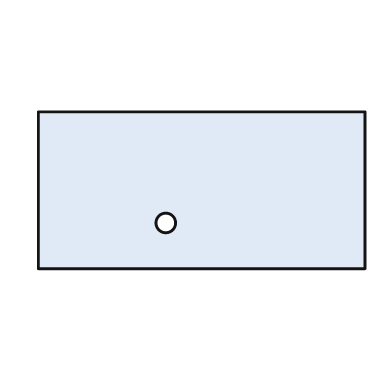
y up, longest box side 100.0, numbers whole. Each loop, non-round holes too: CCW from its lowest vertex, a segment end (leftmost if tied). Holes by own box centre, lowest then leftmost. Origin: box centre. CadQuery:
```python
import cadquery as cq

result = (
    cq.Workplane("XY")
    .moveTo(-50.0, -24.0)
    .lineTo(50.0, -24.0)
    .lineTo(50.0, 24.0)
    .lineTo(-50.0, 24.0)
    .close()
    .moveTo(-11.0, -10.0)
    .circle(3.0)
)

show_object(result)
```